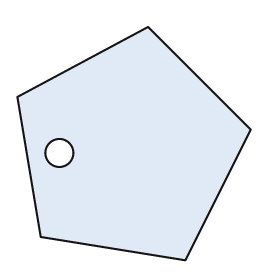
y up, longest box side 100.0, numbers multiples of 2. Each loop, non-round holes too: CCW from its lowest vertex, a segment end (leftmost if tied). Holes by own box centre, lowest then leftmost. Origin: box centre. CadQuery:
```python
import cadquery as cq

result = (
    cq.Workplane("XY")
    .moveTo(22.0, -50.0)
    .lineTo(50.0, 6.0)
    .lineTo(6.0, 50.0)
    .lineTo(-50.0, 20.0)
    .lineTo(-40.0, -40.0)
    .close()
    .moveTo(-32.0, -4.0)
    .circle(6.0)
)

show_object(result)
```